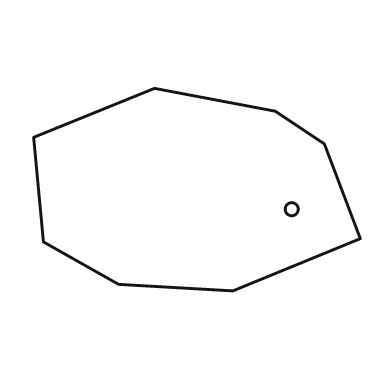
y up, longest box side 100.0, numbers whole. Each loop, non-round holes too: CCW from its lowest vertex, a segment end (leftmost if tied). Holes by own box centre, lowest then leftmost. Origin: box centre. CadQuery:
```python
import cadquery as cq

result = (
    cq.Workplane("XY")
    .moveTo(11.0, -31.0)
    .lineTo(50.0, -15.0)
    .lineTo(39.0, 14.0)
    .lineTo(24.0, 24.0)
    .lineTo(-13.0, 31.0)
    .lineTo(-50.0, 16.0)
    .lineTo(-47.0, -16.0)
    .lineTo(-24.0, -29.0)
    .close()
    .moveTo(29.0, -6.0)
    .circle(2.0)
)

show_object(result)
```